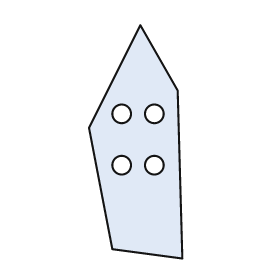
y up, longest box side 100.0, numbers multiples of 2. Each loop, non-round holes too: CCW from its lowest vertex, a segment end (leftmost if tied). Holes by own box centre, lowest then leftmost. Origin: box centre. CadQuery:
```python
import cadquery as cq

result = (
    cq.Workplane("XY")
    .moveTo(20.0, -50.0)
    .lineTo(18.0, 22.0)
    .lineTo(2.0, 50.0)
    .lineTo(-20.0, 6.0)
    .lineTo(-10.0, -46.0)
    .close()
    .moveTo(-6.0, -10.0)
    .circle(4.0)
    .moveTo(8.0, -10.0)
    .circle(4.0)
    .moveTo(-6.0, 12.0)
    .circle(4.0)
    .moveTo(8.0, 12.0)
    .circle(4.0)
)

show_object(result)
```